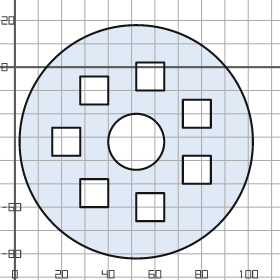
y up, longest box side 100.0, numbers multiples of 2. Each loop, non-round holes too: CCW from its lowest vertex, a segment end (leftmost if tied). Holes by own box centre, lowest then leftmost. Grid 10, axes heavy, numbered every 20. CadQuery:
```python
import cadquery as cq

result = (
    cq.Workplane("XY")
    .moveTo(52.0, -32.0)
    .circle(50.0)
    .moveTo(52.0, -66.0)
    .lineTo(64.0, -66.0)
    .lineTo(64.0, -54.0)
    .lineTo(52.0, -54.0)
    .close()
    .moveTo(28.0, -60.0)
    .lineTo(40.0, -60.0)
    .lineTo(40.0, -48.0)
    .lineTo(28.0, -48.0)
    .close()
    .moveTo(72.0, -50.0)
    .lineTo(84.0, -50.0)
    .lineTo(84.0, -38.0)
    .lineTo(72.0, -38.0)
    .close()
    .moveTo(16.0, -38.0)
    .lineTo(28.0, -38.0)
    .lineTo(28.0, -26.0)
    .lineTo(16.0, -26.0)
    .close()
    .moveTo(52.0, -32.0)
    .circle(12.0)
    .moveTo(72.0, -26.0)
    .lineTo(84.0, -26.0)
    .lineTo(84.0, -14.0)
    .lineTo(72.0, -14.0)
    .close()
    .moveTo(28.0, -16.0)
    .lineTo(40.0, -16.0)
    .lineTo(40.0, -4.0)
    .lineTo(28.0, -4.0)
    .close()
    .moveTo(52.0, -10.0)
    .lineTo(64.0, -10.0)
    .lineTo(64.0, 2.0)
    .lineTo(52.0, 2.0)
    .close()
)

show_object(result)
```